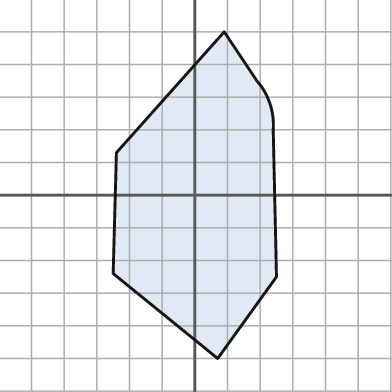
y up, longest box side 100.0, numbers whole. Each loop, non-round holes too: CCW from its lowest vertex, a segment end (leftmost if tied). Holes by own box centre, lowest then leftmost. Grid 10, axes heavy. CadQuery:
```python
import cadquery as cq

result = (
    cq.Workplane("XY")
    .moveTo(7.0, -50.0)
    .lineTo(25.0, -25.0)
    .lineTo(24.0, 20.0)
    .threePointArc((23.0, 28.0), (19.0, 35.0))
    .lineTo(9.0, 50.0)
    .lineTo(-24.0, 13.0)
    .lineTo(-25.0, -24.0)
    .close()
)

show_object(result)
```